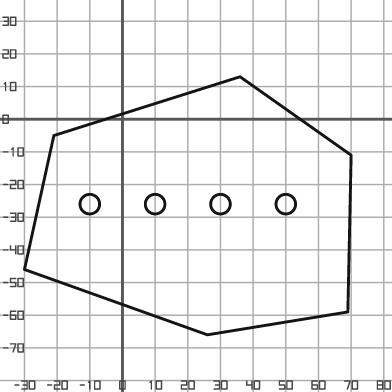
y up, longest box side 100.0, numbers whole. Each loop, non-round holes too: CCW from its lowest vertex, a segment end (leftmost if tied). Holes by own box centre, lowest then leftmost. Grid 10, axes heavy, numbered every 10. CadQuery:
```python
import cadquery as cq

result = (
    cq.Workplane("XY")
    .moveTo(26.0, -66.0)
    .lineTo(69.0, -59.0)
    .lineTo(70.0, -11.0)
    .lineTo(36.0, 13.0)
    .lineTo(-21.0, -5.0)
    .lineTo(-30.0, -46.0)
    .close()
    .moveTo(-10.0, -26.0)
    .circle(3.0)
    .moveTo(10.0, -26.0)
    .circle(3.0)
    .moveTo(30.0, -26.0)
    .circle(3.0)
    .moveTo(50.0, -26.0)
    .circle(3.0)
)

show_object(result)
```